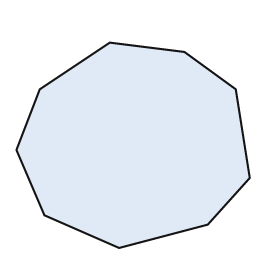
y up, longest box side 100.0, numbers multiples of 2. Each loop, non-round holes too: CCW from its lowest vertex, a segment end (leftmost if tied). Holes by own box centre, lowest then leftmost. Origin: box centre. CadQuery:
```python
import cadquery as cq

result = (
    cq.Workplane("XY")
    .moveTo(-6.0, -44.0)
    .lineTo(32.0, -34.0)
    .lineTo(50.0, -14.0)
    .lineTo(44.0, 24.0)
    .lineTo(22.0, 40.0)
    .lineTo(-10.0, 44.0)
    .lineTo(-40.0, 24.0)
    .lineTo(-50.0, -2.0)
    .lineTo(-38.0, -30.0)
    .close()
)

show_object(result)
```